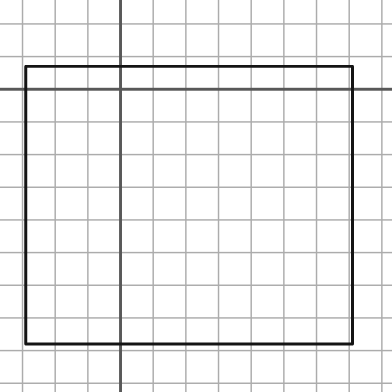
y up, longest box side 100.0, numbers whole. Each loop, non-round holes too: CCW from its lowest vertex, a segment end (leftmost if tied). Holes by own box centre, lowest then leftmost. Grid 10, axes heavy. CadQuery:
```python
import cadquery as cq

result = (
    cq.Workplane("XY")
    .moveTo(-29.0, -78.0)
    .lineTo(71.0, -78.0)
    .lineTo(71.0, 7.0)
    .lineTo(-29.0, 7.0)
    .close()
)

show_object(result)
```